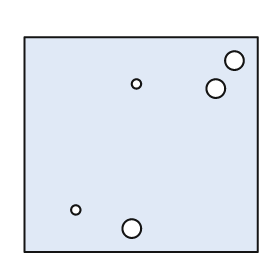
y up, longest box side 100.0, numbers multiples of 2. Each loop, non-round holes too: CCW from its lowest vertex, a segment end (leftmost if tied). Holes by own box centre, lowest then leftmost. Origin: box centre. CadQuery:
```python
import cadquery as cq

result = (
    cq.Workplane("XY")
    .moveTo(-50.0, -46.0)
    .lineTo(50.0, -46.0)
    .lineTo(50.0, 46.0)
    .lineTo(-50.0, 46.0)
    .close()
    .moveTo(-4.0, -36.0)
    .circle(4.0)
    .moveTo(-28.0, -28.0)
    .circle(2.0)
    .moveTo(32.0, 24.0)
    .circle(4.0)
    .moveTo(-2.0, 26.0)
    .circle(2.0)
    .moveTo(40.0, 36.0)
    .circle(4.0)
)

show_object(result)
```